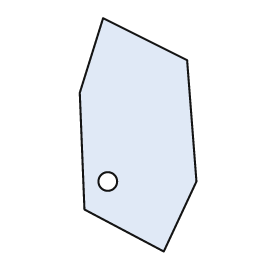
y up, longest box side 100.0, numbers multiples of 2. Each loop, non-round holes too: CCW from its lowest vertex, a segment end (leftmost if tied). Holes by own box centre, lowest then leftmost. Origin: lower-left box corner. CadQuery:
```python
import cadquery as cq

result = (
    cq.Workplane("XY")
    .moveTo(36.0, 0.0)
    .lineTo(50.0, 30.0)
    .lineTo(46.0, 82.0)
    .lineTo(10.0, 100.0)
    .lineTo(0.0, 68.0)
    .lineTo(2.0, 18.0)
    .close()
    .moveTo(12.0, 30.0)
    .circle(4.0)
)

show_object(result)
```